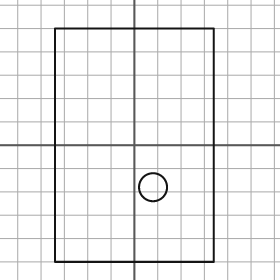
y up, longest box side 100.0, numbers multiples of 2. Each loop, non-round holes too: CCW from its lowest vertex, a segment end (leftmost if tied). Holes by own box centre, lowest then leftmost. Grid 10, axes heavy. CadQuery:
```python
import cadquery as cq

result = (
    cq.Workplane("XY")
    .moveTo(-34.0, -50.0)
    .lineTo(34.0, -50.0)
    .lineTo(34.0, 50.0)
    .lineTo(-34.0, 50.0)
    .close()
    .moveTo(8.0, -18.0)
    .circle(6.0)
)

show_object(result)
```